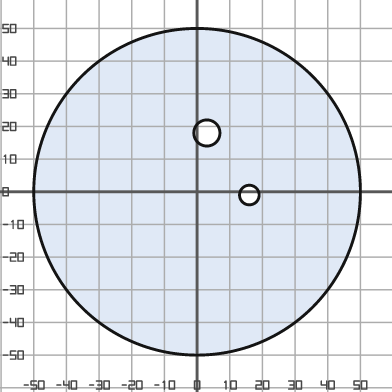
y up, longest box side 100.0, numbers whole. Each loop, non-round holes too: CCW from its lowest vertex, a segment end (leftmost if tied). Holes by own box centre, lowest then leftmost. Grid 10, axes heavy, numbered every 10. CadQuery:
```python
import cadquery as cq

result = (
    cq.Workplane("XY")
    .moveTo(0.0, 0.0)
    .circle(50.0)
    .moveTo(16.0, -1.0)
    .circle(3.0)
    .moveTo(3.0, 18.0)
    .circle(4.0)
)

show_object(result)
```